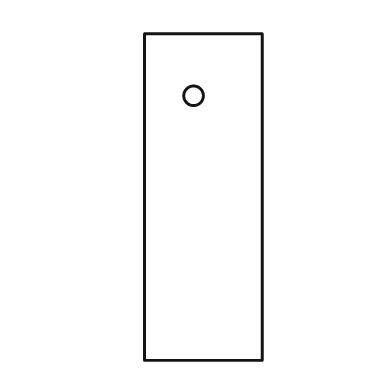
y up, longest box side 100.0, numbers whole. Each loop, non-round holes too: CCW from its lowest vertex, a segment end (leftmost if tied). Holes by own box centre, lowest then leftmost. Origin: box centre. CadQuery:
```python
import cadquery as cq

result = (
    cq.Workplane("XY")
    .moveTo(-18.0, -50.0)
    .lineTo(18.0, -50.0)
    .lineTo(18.0, 50.0)
    .lineTo(-18.0, 50.0)
    .close()
    .moveTo(-3.0, 31.0)
    .circle(3.0)
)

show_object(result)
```